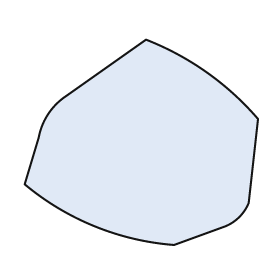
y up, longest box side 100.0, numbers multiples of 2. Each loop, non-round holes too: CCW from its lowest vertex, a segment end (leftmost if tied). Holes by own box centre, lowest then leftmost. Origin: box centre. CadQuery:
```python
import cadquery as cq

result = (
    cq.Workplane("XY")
    .moveTo(14.0, -44.0)
    .lineTo(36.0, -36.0)
    .threePointArc((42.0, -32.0), (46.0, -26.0))
    .lineTo(50.0, 10.0)
    .threePointArc((28.0, 30.0), (2.0, 44.0))
    .lineTo(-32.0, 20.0)
    .threePointArc((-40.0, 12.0), (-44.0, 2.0))
    .lineTo(-50.0, -18.0)
    .threePointArc((-20.0, -36.0), (14.0, -44.0))
    .close()
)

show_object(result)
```